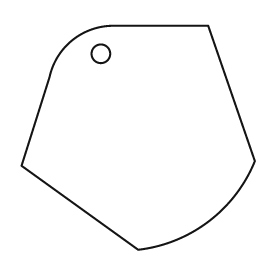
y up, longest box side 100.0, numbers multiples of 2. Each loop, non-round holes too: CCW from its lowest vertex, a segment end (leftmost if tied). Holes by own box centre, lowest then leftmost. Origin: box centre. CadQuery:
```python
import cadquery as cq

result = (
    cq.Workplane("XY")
    .moveTo(0.0, -48.0)
    .threePointArc((30.0, -36.0), (50.0, -10.0))
    .lineTo(30.0, 48.0)
    .lineTo(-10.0, 48.0)
    .threePointArc((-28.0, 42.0), (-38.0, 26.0))
    .lineTo(-50.0, -12.0)
    .close()
    .moveTo(-16.0, 36.0)
    .circle(4.0)
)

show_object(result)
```